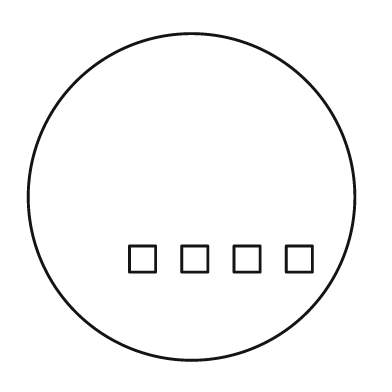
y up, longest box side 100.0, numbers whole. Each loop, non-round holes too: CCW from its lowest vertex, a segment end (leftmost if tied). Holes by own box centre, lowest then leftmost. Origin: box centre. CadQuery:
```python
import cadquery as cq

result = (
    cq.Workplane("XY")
    .moveTo(0.0, 0.0)
    .circle(50.0)
    .moveTo(-19.0, -23.0)
    .lineTo(-11.0, -23.0)
    .lineTo(-11.0, -15.0)
    .lineTo(-19.0, -15.0)
    .close()
    .moveTo(-3.0, -23.0)
    .lineTo(5.0, -23.0)
    .lineTo(5.0, -15.0)
    .lineTo(-3.0, -15.0)
    .close()
    .moveTo(13.0, -23.0)
    .lineTo(21.0, -23.0)
    .lineTo(21.0, -15.0)
    .lineTo(13.0, -15.0)
    .close()
    .moveTo(29.0, -23.0)
    .lineTo(37.0, -23.0)
    .lineTo(37.0, -15.0)
    .lineTo(29.0, -15.0)
    .close()
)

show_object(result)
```